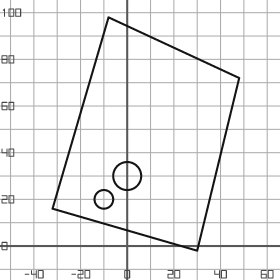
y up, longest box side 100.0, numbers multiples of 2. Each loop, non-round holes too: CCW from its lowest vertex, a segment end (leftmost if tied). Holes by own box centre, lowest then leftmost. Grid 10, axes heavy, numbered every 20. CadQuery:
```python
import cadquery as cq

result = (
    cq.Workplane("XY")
    .moveTo(30.0, -2.0)
    .lineTo(48.0, 72.0)
    .lineTo(-8.0, 98.0)
    .lineTo(-32.0, 16.0)
    .close()
    .moveTo(-10.0, 20.0)
    .circle(4.0)
    .moveTo(0.0, 30.0)
    .circle(6.0)
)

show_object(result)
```